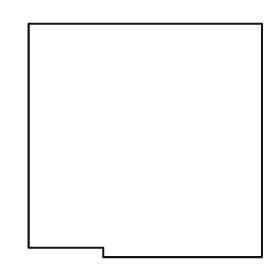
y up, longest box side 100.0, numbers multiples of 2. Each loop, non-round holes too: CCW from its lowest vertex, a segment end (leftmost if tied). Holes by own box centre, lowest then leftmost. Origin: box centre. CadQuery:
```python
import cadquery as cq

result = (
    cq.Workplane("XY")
    .moveTo(-18.0, -50.0)
    .lineTo(50.0, -50.0)
    .lineTo(50.0, 50.0)
    .lineTo(-50.0, 50.0)
    .lineTo(-50.0, -46.0)
    .lineTo(-18.0, -46.0)
    .close()
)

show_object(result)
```